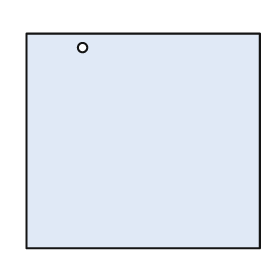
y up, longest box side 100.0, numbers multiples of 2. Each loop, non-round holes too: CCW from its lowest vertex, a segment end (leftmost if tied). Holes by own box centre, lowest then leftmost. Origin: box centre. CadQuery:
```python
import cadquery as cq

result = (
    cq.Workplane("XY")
    .moveTo(-50.0, -46.0)
    .lineTo(50.0, -46.0)
    .lineTo(50.0, 46.0)
    .lineTo(-50.0, 46.0)
    .close()
    .moveTo(-26.0, 40.0)
    .circle(2.0)
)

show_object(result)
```